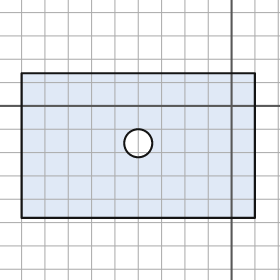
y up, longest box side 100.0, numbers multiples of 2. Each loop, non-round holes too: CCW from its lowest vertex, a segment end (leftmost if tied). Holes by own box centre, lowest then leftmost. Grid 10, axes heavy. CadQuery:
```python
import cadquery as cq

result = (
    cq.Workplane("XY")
    .moveTo(-90.0, -48.0)
    .lineTo(10.0, -48.0)
    .lineTo(10.0, 14.0)
    .lineTo(-90.0, 14.0)
    .close()
    .moveTo(-40.0, -16.0)
    .circle(6.0)
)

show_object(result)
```